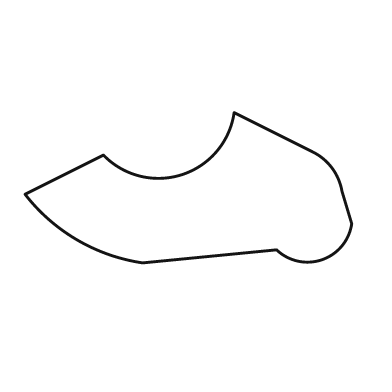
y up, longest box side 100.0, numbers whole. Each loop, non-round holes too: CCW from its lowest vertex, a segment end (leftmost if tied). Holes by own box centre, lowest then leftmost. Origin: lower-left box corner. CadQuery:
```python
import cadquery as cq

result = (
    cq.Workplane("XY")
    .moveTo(36.0, 0.0)
    .lineTo(77.0, 4.0)
    .threePointArc((91.0, 1.0), (100.0, 12.0))
    .lineTo(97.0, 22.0)
    .threePointArc((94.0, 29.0), (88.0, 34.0))
    .lineTo(64.0, 46.0)
    .threePointArc((48.0, 27.0), (24.0, 33.0))
    .lineTo(0.0, 21.0)
    .threePointArc((16.0, 7.0), (36.0, 0.0))
    .close()
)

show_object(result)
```